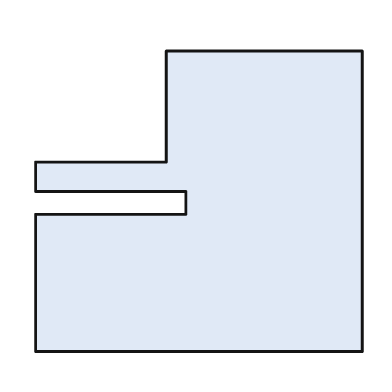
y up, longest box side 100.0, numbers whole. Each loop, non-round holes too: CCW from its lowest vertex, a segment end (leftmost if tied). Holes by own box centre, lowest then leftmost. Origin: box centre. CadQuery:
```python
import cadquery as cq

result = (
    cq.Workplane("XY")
    .moveTo(-50.0, -46.0)
    .lineTo(50.0, -46.0)
    .lineTo(50.0, 46.0)
    .lineTo(-10.0, 46.0)
    .lineTo(-10.0, 12.0)
    .lineTo(-50.0, 12.0)
    .lineTo(-50.0, 3.0)
    .lineTo(-4.0, 3.0)
    .lineTo(-4.0, -4.0)
    .lineTo(-50.0, -4.0)
    .close()
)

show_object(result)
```